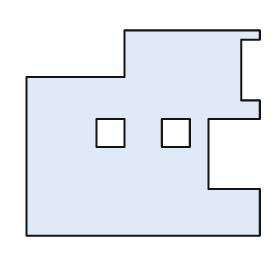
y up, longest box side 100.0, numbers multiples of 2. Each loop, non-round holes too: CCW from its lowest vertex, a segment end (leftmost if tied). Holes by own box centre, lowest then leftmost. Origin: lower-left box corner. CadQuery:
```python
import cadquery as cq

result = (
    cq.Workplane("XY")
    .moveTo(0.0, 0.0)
    .lineTo(100.0, 0.0)
    .lineTo(100.0, 20.0)
    .lineTo(78.0, 20.0)
    .lineTo(78.0, 50.0)
    .lineTo(100.0, 50.0)
    .lineTo(100.0, 58.0)
    .lineTo(92.0, 58.0)
    .lineTo(92.0, 84.0)
    .lineTo(100.0, 84.0)
    .lineTo(100.0, 88.0)
    .lineTo(42.0, 88.0)
    .lineTo(42.0, 68.0)
    .lineTo(0.0, 68.0)
    .close()
    .moveTo(30.0, 38.0)
    .lineTo(42.0, 38.0)
    .lineTo(42.0, 50.0)
    .lineTo(30.0, 50.0)
    .close()
    .moveTo(58.0, 38.0)
    .lineTo(70.0, 38.0)
    .lineTo(70.0, 50.0)
    .lineTo(58.0, 50.0)
    .close()
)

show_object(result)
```